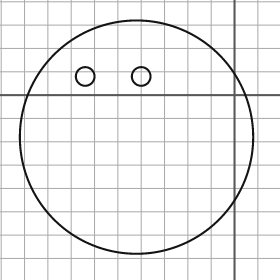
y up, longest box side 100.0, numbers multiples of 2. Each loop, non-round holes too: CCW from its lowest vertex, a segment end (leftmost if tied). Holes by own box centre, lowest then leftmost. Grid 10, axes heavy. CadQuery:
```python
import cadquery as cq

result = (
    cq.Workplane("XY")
    .moveTo(-42.0, -18.0)
    .circle(50.0)
    .moveTo(-64.0, 8.0)
    .circle(4.0)
    .moveTo(-40.0, 8.0)
    .circle(4.0)
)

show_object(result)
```